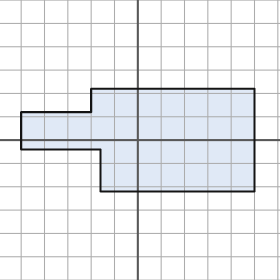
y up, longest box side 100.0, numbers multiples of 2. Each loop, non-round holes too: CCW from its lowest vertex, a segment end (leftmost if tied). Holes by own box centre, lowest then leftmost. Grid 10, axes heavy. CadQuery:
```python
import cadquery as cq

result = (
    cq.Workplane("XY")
    .moveTo(-16.0, -22.0)
    .lineTo(50.0, -22.0)
    .lineTo(50.0, 22.0)
    .lineTo(-20.0, 22.0)
    .lineTo(-20.0, 12.0)
    .lineTo(-50.0, 12.0)
    .lineTo(-50.0, -4.0)
    .lineTo(-16.0, -4.0)
    .close()
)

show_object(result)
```